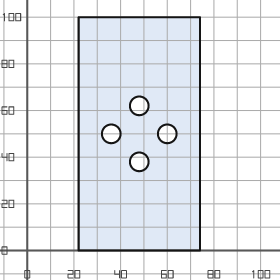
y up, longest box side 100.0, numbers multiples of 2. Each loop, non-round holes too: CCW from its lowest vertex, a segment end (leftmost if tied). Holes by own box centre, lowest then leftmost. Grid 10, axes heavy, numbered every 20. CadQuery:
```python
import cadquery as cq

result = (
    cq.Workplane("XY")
    .moveTo(22.0, 0.0)
    .lineTo(74.0, 0.0)
    .lineTo(74.0, 100.0)
    .lineTo(22.0, 100.0)
    .close()
    .moveTo(48.0, 38.0)
    .circle(4.0)
    .moveTo(36.0, 50.0)
    .circle(4.0)
    .moveTo(60.0, 50.0)
    .circle(4.0)
    .moveTo(48.0, 62.0)
    .circle(4.0)
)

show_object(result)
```